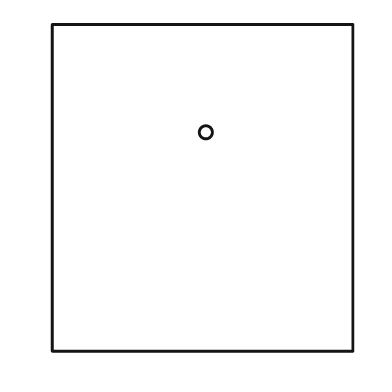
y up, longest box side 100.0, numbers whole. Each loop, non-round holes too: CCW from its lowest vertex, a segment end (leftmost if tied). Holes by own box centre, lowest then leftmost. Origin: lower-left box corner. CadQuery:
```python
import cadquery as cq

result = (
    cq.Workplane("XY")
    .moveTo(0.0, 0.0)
    .lineTo(92.0, 0.0)
    .lineTo(92.0, 100.0)
    .lineTo(0.0, 100.0)
    .close()
    .moveTo(47.0, 67.0)
    .circle(2.0)
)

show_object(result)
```